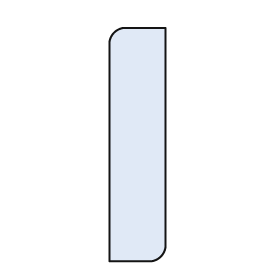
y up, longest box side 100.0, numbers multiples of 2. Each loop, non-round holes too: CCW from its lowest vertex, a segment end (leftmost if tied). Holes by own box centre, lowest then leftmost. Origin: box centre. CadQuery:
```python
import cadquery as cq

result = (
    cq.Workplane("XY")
    .moveTo(-12.0, -50.0)
    .lineTo(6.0, -50.0)
    .threePointArc((10.0, -48.0), (12.0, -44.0))
    .lineTo(12.0, 50.0)
    .lineTo(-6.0, 50.0)
    .threePointArc((-10.0, 48.0), (-12.0, 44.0))
    .close()
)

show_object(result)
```